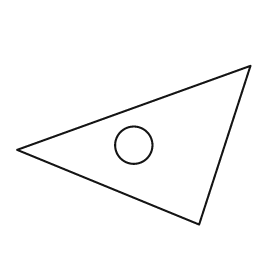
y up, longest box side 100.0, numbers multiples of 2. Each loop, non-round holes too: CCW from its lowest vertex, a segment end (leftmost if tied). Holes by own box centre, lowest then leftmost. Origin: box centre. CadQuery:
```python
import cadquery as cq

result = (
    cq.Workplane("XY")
    .moveTo(28.0, -34.0)
    .lineTo(50.0, 34.0)
    .lineTo(-50.0, -2.0)
    .close()
    .moveTo(0.0, 0.0)
    .circle(8.0)
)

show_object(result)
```